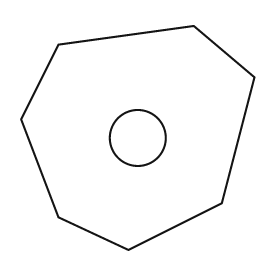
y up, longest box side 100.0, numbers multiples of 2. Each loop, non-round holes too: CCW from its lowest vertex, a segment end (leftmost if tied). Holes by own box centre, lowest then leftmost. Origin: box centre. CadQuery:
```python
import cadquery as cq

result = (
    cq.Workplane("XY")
    .moveTo(-4.0, -48.0)
    .lineTo(36.0, -28.0)
    .lineTo(50.0, 26.0)
    .lineTo(24.0, 48.0)
    .lineTo(-34.0, 40.0)
    .lineTo(-50.0, 8.0)
    .lineTo(-34.0, -34.0)
    .close()
    .moveTo(0.0, 0.0)
    .circle(12.0)
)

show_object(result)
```